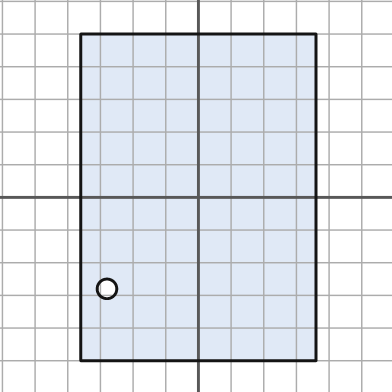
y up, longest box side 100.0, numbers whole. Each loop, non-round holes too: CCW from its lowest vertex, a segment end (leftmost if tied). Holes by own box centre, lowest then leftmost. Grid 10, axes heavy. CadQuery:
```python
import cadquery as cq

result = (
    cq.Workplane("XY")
    .moveTo(-36.0, -50.0)
    .lineTo(36.0, -50.0)
    .lineTo(36.0, 50.0)
    .lineTo(-36.0, 50.0)
    .close()
    .moveTo(-28.0, -28.0)
    .circle(3.0)
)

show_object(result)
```